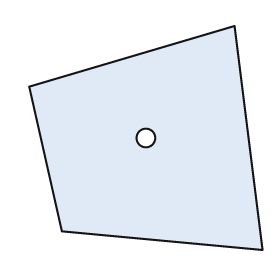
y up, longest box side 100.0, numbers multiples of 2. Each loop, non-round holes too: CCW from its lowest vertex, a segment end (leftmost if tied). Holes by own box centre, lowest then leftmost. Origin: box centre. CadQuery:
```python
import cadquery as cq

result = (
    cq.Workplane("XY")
    .moveTo(50.0, -48.0)
    .lineTo(38.0, 48.0)
    .lineTo(-50.0, 22.0)
    .lineTo(-36.0, -40.0)
    .close()
    .moveTo(0.0, 0.0)
    .circle(4.0)
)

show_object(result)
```